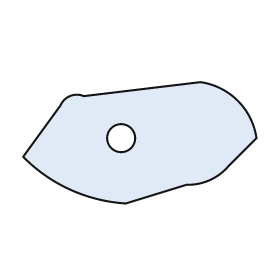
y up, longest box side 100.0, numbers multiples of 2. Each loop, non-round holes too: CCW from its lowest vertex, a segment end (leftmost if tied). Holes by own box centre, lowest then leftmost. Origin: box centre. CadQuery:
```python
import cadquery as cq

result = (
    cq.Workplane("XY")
    .moveTo(-6.0, -26.0)
    .lineTo(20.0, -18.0)
    .threePointArc((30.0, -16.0), (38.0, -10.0))
    .lineTo(50.0, 2.0)
    .threePointArc((42.0, 18.0), (26.0, 26.0))
    .lineTo(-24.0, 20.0)
    .threePointArc((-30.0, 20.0), (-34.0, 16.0))
    .lineTo(-50.0, -6.0)
    .threePointArc((-30.0, -20.0), (-6.0, -26.0))
    .close()
    .moveTo(-8.0, 2.0)
    .circle(6.0)
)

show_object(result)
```